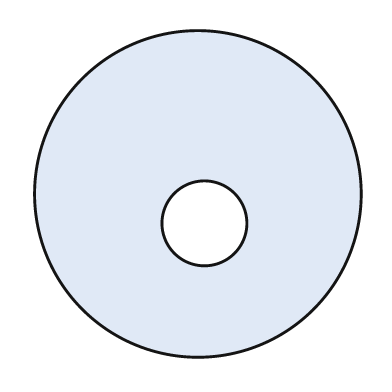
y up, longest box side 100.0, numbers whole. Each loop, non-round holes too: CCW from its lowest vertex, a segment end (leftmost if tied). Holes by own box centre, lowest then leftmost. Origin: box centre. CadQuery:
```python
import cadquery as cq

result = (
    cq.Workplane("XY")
    .moveTo(0.0, 0.0)
    .circle(50.0)
    .moveTo(2.0, -9.0)
    .circle(13.0)
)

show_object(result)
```